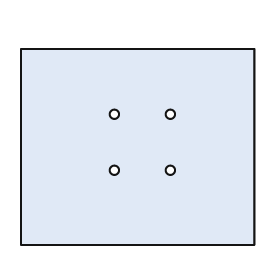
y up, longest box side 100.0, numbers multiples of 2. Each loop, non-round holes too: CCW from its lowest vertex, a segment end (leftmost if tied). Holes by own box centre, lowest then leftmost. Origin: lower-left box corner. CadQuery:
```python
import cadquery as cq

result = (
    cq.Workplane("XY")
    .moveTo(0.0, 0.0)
    .lineTo(100.0, 0.0)
    .lineTo(100.0, 84.0)
    .lineTo(0.0, 84.0)
    .close()
    .moveTo(40.0, 32.0)
    .circle(2.0)
    .moveTo(64.0, 32.0)
    .circle(2.0)
    .moveTo(40.0, 56.0)
    .circle(2.0)
    .moveTo(64.0, 56.0)
    .circle(2.0)
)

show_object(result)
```